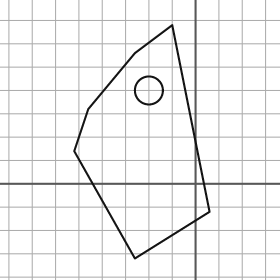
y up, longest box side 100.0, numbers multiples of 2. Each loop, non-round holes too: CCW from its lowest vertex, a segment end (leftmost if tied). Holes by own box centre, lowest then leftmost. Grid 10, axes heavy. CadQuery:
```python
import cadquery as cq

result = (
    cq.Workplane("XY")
    .moveTo(-26.0, -32.0)
    .lineTo(6.0, -12.0)
    .lineTo(-10.0, 68.0)
    .lineTo(-26.0, 56.0)
    .lineTo(-46.0, 32.0)
    .lineTo(-52.0, 14.0)
    .close()
    .moveTo(-20.0, 40.0)
    .circle(6.0)
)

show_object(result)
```